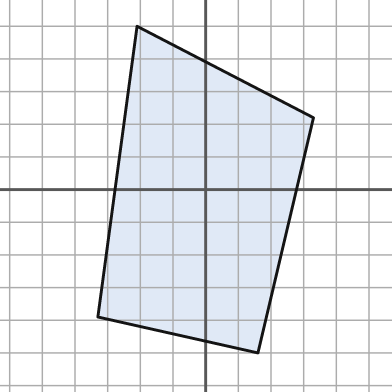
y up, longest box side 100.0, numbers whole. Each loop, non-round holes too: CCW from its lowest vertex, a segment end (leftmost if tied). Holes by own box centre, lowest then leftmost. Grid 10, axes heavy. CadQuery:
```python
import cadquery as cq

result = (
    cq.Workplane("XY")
    .moveTo(16.0, -50.0)
    .lineTo(33.0, 22.0)
    .lineTo(-21.0, 50.0)
    .lineTo(-33.0, -39.0)
    .close()
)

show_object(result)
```